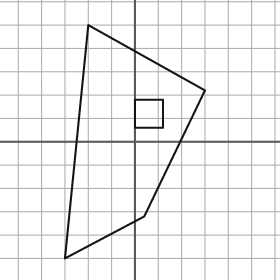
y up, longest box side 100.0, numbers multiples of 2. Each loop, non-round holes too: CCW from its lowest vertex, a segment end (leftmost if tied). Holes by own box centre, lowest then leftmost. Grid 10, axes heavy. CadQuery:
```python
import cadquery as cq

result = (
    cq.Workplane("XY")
    .moveTo(-30.0, -50.0)
    .lineTo(4.0, -32.0)
    .lineTo(30.0, 22.0)
    .lineTo(-20.0, 50.0)
    .close()
    .moveTo(0.0, 6.0)
    .lineTo(12.0, 6.0)
    .lineTo(12.0, 18.0)
    .lineTo(0.0, 18.0)
    .close()
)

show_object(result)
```